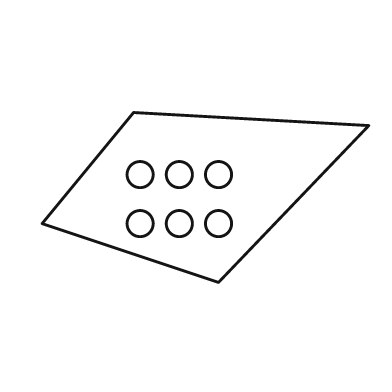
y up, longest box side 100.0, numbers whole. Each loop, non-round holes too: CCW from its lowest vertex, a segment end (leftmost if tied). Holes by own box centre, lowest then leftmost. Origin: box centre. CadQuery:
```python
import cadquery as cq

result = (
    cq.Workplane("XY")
    .moveTo(4.0, -26.0)
    .lineTo(50.0, 22.0)
    .lineTo(-22.0, 26.0)
    .lineTo(-50.0, -8.0)
    .close()
    .moveTo(-20.0, -8.0)
    .circle(4.0)
    .moveTo(-8.0, -8.0)
    .circle(4.0)
    .moveTo(4.0, -8.0)
    .circle(4.0)
    .moveTo(-20.0, 7.0)
    .circle(4.0)
    .moveTo(-8.0, 7.0)
    .circle(4.0)
    .moveTo(4.0, 7.0)
    .circle(4.0)
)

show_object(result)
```